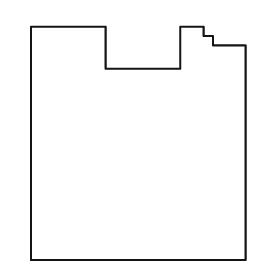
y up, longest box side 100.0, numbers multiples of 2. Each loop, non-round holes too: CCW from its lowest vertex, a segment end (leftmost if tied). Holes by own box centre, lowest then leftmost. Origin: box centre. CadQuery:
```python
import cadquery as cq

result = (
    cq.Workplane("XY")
    .moveTo(-46.0, -50.0)
    .lineTo(46.0, -50.0)
    .lineTo(46.0, 42.0)
    .lineTo(32.0, 42.0)
    .lineTo(32.0, 46.0)
    .lineTo(28.0, 46.0)
    .lineTo(28.0, 50.0)
    .lineTo(18.0, 50.0)
    .lineTo(18.0, 32.0)
    .lineTo(-14.0, 32.0)
    .lineTo(-14.0, 50.0)
    .lineTo(-46.0, 50.0)
    .close()
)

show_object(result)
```